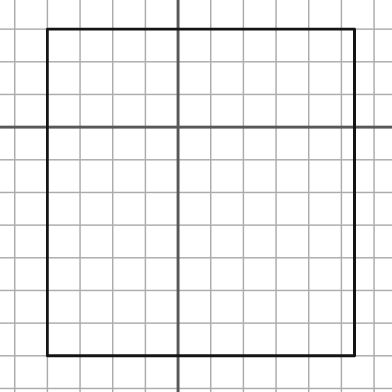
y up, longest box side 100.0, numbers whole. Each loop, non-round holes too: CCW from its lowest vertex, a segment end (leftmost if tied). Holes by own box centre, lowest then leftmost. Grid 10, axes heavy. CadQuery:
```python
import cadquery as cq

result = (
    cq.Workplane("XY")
    .moveTo(-40.0, -70.0)
    .lineTo(54.0, -70.0)
    .lineTo(54.0, 30.0)
    .lineTo(-40.0, 30.0)
    .close()
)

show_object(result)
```